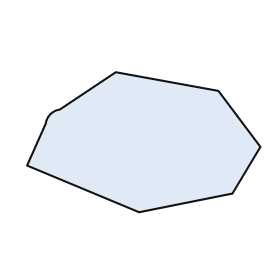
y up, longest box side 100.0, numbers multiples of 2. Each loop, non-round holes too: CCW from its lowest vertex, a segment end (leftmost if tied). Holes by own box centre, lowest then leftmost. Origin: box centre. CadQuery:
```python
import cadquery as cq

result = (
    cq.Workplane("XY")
    .moveTo(-2.0, -30.0)
    .lineTo(38.0, -22.0)
    .lineTo(50.0, -2.0)
    .lineTo(32.0, 22.0)
    .lineTo(-12.0, 30.0)
    .lineTo(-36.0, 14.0)
    .threePointArc((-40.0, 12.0), (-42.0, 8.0))
    .lineTo(-50.0, -10.0)
    .close()
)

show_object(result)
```